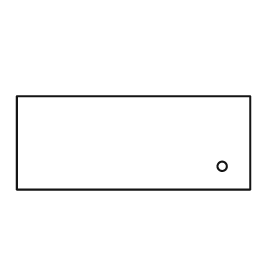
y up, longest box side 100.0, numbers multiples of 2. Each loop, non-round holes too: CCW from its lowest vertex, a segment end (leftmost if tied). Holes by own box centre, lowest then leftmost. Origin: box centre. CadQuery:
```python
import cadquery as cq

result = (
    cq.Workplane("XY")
    .moveTo(-50.0, -20.0)
    .lineTo(50.0, -20.0)
    .lineTo(50.0, 20.0)
    .lineTo(-50.0, 20.0)
    .close()
    .moveTo(38.0, -10.0)
    .circle(2.0)
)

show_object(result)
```